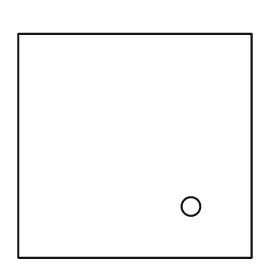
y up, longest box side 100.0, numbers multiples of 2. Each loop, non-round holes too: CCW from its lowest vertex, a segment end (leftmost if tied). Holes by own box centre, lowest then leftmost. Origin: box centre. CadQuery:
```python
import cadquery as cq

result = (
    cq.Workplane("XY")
    .moveTo(-50.0, -48.0)
    .lineTo(50.0, -48.0)
    .lineTo(50.0, 48.0)
    .lineTo(-50.0, 48.0)
    .close()
    .moveTo(24.0, -26.0)
    .circle(4.0)
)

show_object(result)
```